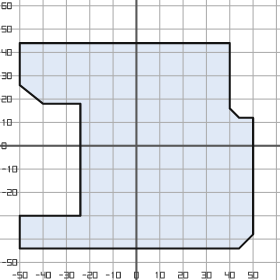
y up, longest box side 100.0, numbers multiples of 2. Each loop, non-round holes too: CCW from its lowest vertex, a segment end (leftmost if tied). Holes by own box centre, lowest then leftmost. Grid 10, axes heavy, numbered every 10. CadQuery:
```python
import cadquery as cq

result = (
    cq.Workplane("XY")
    .moveTo(-50.0, -44.0)
    .lineTo(44.0, -44.0)
    .lineTo(50.0, -38.0)
    .lineTo(50.0, 12.0)
    .lineTo(44.0, 12.0)
    .lineTo(40.0, 16.0)
    .lineTo(40.0, 44.0)
    .lineTo(-50.0, 44.0)
    .lineTo(-50.0, 26.0)
    .lineTo(-40.0, 18.0)
    .lineTo(-24.0, 18.0)
    .lineTo(-24.0, -30.0)
    .lineTo(-50.0, -30.0)
    .close()
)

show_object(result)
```